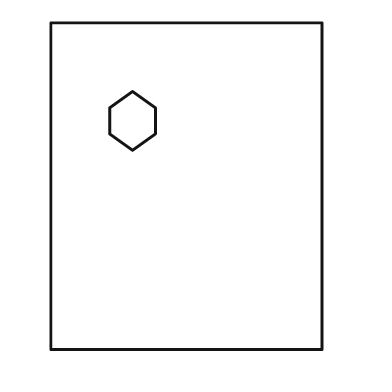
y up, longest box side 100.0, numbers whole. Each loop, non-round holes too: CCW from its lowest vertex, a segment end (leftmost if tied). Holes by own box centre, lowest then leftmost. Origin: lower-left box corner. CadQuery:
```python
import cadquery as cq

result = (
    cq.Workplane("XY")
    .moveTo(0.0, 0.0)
    .lineTo(83.0, 0.0)
    .lineTo(83.0, 100.0)
    .lineTo(0.0, 100.0)
    .close()
    .moveTo(25.0, 61.0)
    .lineTo(32.0, 66.0)
    .lineTo(32.0, 74.0)
    .lineTo(25.0, 79.0)
    .lineTo(18.0, 74.0)
    .lineTo(18.0, 66.0)
    .close()
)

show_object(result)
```